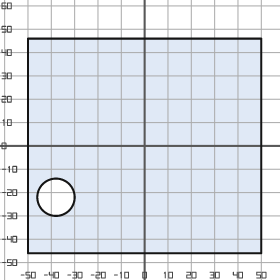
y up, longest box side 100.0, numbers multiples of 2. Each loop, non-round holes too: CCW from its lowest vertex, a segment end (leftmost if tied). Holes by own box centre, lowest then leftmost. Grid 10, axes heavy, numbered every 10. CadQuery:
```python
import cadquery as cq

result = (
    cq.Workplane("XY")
    .moveTo(-50.0, -46.0)
    .lineTo(50.0, -46.0)
    .lineTo(50.0, 46.0)
    .lineTo(-50.0, 46.0)
    .close()
    .moveTo(-38.0, -22.0)
    .circle(8.0)
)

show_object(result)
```